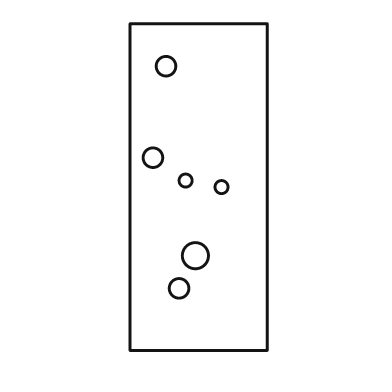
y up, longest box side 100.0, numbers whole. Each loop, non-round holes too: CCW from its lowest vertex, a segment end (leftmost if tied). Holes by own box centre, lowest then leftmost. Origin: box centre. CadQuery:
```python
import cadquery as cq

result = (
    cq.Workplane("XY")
    .moveTo(-21.0, -50.0)
    .lineTo(21.0, -50.0)
    .lineTo(21.0, 50.0)
    .lineTo(-21.0, 50.0)
    .close()
    .moveTo(-6.0, -31.0)
    .circle(3.0)
    .moveTo(-1.0, -21.0)
    .circle(4.0)
    .moveTo(7.0, 0.0)
    .circle(2.0)
    .moveTo(-4.0, 2.0)
    .circle(2.0)
    .moveTo(-14.0, 9.0)
    .circle(3.0)
    .moveTo(-10.0, 37.0)
    .circle(3.0)
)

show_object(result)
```